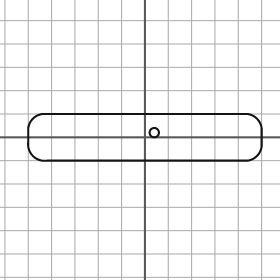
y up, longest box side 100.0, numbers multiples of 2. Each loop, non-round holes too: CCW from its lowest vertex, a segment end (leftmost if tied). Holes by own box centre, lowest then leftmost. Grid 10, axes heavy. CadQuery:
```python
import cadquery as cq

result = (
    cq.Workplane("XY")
    .moveTo(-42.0, -10.0)
    .lineTo(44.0, -10.0)
    .threePointArc((48.0, -8.0), (50.0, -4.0))
    .lineTo(50.0, 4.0)
    .threePointArc((48.0, 8.0), (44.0, 10.0))
    .lineTo(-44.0, 10.0)
    .threePointArc((-48.0, 8.0), (-50.0, 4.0))
    .lineTo(-50.0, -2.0)
    .threePointArc((-48.0, -8.0), (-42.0, -10.0))
    .close()
    .moveTo(4.0, 2.0)
    .circle(2.0)
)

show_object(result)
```